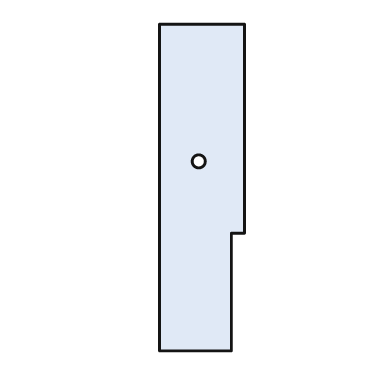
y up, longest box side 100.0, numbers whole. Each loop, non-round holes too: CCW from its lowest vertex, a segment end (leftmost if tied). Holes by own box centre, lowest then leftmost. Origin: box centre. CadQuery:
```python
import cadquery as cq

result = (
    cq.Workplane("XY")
    .moveTo(-13.0, -50.0)
    .lineTo(9.0, -50.0)
    .lineTo(9.0, -14.0)
    .lineTo(13.0, -14.0)
    .lineTo(13.0, 50.0)
    .lineTo(-13.0, 50.0)
    .close()
    .moveTo(-1.0, 8.0)
    .circle(2.0)
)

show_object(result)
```